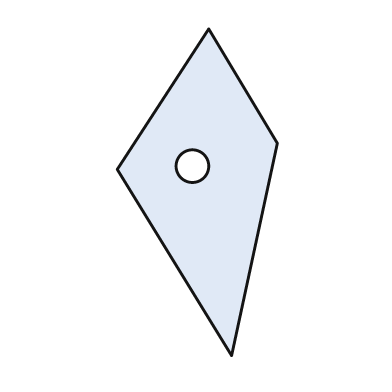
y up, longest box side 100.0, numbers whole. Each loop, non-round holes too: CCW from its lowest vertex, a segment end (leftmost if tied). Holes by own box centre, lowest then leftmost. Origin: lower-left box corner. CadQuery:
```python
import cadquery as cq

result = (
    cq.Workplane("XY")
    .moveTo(35.0, 0.0)
    .lineTo(49.0, 65.0)
    .lineTo(28.0, 100.0)
    .lineTo(0.0, 57.0)
    .close()
    .moveTo(23.0, 58.0)
    .circle(5.0)
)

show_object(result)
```